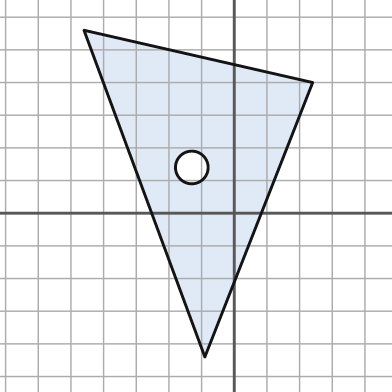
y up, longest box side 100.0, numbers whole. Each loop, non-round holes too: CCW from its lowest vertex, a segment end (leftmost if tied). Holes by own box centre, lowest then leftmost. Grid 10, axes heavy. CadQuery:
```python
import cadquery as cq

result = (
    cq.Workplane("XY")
    .moveTo(-9.0, -44.0)
    .lineTo(24.0, 40.0)
    .lineTo(-46.0, 56.0)
    .close()
    .moveTo(-13.0, 14.0)
    .circle(5.0)
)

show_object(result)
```